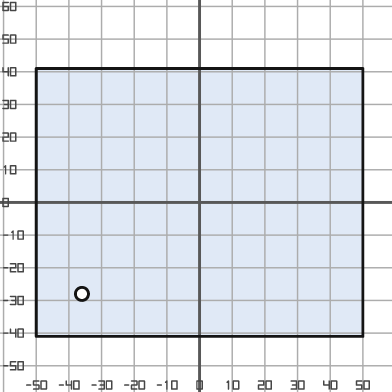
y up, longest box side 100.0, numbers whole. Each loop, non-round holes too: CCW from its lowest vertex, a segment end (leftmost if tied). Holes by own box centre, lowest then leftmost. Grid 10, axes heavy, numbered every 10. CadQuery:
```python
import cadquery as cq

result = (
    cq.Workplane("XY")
    .moveTo(-50.0, -41.0)
    .lineTo(50.0, -41.0)
    .lineTo(50.0, 41.0)
    .lineTo(-50.0, 41.0)
    .close()
    .moveTo(-36.0, -28.0)
    .circle(2.0)
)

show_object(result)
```